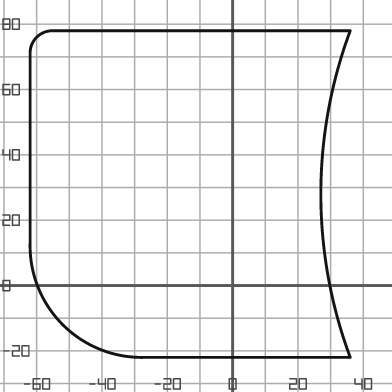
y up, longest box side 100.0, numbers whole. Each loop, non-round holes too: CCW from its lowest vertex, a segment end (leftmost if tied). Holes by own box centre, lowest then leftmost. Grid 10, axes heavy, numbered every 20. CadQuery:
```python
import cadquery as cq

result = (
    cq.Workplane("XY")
    .moveTo(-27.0, -22.0)
    .lineTo(36.0, -22.0)
    .threePointArc((27.0, 28.0), (36.0, 78.0))
    .lineTo(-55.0, 78.0)
    .threePointArc((-60.0, 76.0), (-62.0, 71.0))
    .lineTo(-62.0, 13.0)
    .threePointArc((-52.0, -12.0), (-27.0, -22.0))
    .close()
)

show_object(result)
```